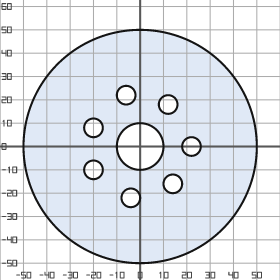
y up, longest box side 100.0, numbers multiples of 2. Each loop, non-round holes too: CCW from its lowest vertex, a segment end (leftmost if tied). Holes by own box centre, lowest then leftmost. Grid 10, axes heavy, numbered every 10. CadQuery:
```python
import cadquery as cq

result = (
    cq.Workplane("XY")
    .moveTo(0.0, 0.0)
    .circle(50.0)
    .moveTo(-4.0, -22.0)
    .circle(4.0)
    .moveTo(14.0, -16.0)
    .circle(4.0)
    .moveTo(-20.0, -10.0)
    .circle(4.0)
    .moveTo(0.0, 0.0)
    .circle(10.0)
    .moveTo(22.0, 0.0)
    .circle(4.0)
    .moveTo(-20.0, 8.0)
    .circle(4.0)
    .moveTo(12.0, 18.0)
    .circle(4.0)
    .moveTo(-6.0, 22.0)
    .circle(4.0)
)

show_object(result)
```